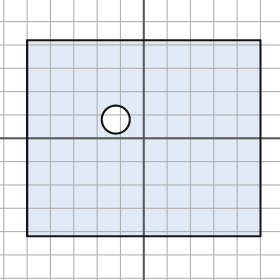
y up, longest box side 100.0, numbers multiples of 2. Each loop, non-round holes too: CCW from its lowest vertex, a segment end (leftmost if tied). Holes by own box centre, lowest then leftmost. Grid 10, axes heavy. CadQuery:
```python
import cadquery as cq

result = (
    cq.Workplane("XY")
    .moveTo(-50.0, -42.0)
    .lineTo(50.0, -42.0)
    .lineTo(50.0, 42.0)
    .lineTo(-50.0, 42.0)
    .close()
    .moveTo(-12.0, 8.0)
    .circle(6.0)
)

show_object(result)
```